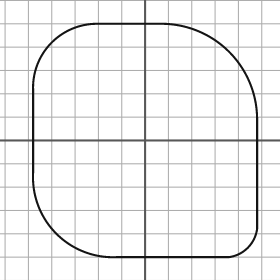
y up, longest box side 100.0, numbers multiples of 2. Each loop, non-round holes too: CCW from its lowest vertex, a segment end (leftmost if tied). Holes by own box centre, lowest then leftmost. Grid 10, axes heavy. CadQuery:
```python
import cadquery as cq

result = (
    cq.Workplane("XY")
    .moveTo(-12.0, -50.0)
    .lineTo(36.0, -50.0)
    .threePointArc((44.0, -46.0), (48.0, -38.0))
    .lineTo(48.0, 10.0)
    .threePointArc((36.0, 38.0), (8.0, 50.0))
    .lineTo(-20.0, 50.0)
    .threePointArc((-40.0, 42.0), (-48.0, 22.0))
    .lineTo(-48.0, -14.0)
    .threePointArc((-38.0, -40.0), (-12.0, -50.0))
    .close()
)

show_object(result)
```